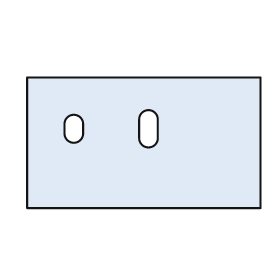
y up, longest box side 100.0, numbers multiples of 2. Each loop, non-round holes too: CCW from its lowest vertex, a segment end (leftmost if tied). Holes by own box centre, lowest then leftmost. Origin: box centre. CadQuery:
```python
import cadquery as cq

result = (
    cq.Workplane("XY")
    .moveTo(-50.0, -28.0)
    .lineTo(50.0, -28.0)
    .lineTo(50.0, 28.0)
    .lineTo(-50.0, 28.0)
    .close()
    .moveTo(-34.0, 4.0)
    .threePointArc((-30.0, 0.0), (-26.0, 4.0))
    .lineTo(-26.0, 8.0)
    .threePointArc((-30.0, 12.0), (-34.0, 8.0))
    .close()
    .moveTo(-2.0, 2.0)
    .threePointArc((2.0, -2.0), (6.0, 2.0))
    .lineTo(6.0, 10.0)
    .threePointArc((2.0, 14.0), (-2.0, 10.0))
    .close()
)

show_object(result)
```